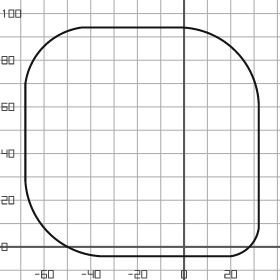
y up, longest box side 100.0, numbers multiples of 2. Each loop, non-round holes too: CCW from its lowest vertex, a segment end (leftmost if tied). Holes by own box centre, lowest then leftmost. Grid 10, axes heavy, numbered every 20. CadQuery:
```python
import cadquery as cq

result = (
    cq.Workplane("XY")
    .moveTo(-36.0, -4.0)
    .lineTo(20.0, -4.0)
    .threePointArc((28.0, 0.0), (32.0, 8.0))
    .lineTo(32.0, 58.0)
    .threePointArc((22.0, 84.0), (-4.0, 94.0))
    .lineTo(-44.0, 94.0)
    .threePointArc((-60.0, 86.0), (-68.0, 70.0))
    .lineTo(-68.0, 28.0)
    .threePointArc((-58.0, 6.0), (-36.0, -4.0))
    .close()
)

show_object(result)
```